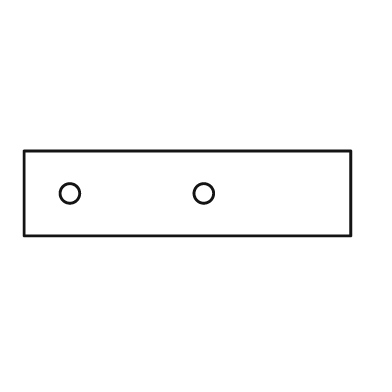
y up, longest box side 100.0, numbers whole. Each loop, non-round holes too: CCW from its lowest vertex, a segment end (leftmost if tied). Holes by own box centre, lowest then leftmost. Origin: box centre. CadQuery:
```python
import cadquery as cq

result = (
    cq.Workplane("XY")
    .moveTo(-50.0, -13.0)
    .lineTo(50.0, -13.0)
    .lineTo(50.0, 13.0)
    .lineTo(-50.0, 13.0)
    .close()
    .moveTo(-36.0, 0.0)
    .circle(3.0)
    .moveTo(5.0, 0.0)
    .circle(3.0)
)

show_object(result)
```